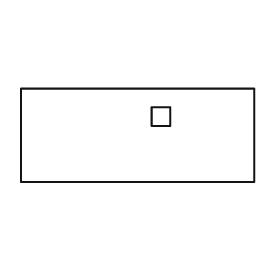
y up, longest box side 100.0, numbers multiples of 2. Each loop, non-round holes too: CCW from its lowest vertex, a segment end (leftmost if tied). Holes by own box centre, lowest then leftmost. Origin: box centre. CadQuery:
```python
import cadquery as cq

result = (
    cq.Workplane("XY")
    .moveTo(-50.0, -20.0)
    .lineTo(50.0, -20.0)
    .lineTo(50.0, 20.0)
    .lineTo(-50.0, 20.0)
    .close()
    .moveTo(6.0, 4.0)
    .lineTo(14.0, 4.0)
    .lineTo(14.0, 12.0)
    .lineTo(6.0, 12.0)
    .close()
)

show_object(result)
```